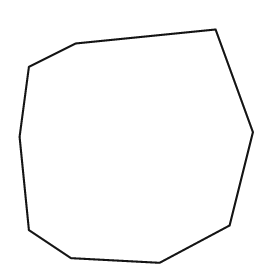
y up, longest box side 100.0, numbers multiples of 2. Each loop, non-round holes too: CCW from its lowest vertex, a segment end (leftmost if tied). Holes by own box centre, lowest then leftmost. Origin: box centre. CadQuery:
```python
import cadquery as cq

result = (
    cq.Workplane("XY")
    .moveTo(10.0, -50.0)
    .lineTo(40.0, -34.0)
    .lineTo(50.0, 6.0)
    .lineTo(34.0, 50.0)
    .lineTo(-26.0, 44.0)
    .lineTo(-46.0, 34.0)
    .lineTo(-50.0, 4.0)
    .lineTo(-46.0, -36.0)
    .lineTo(-28.0, -48.0)
    .close()
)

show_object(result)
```